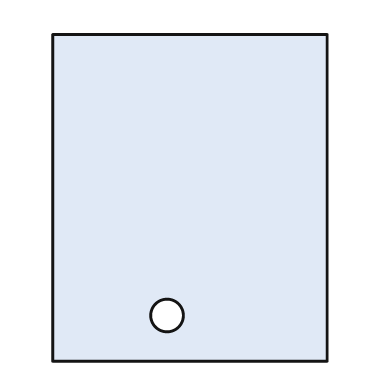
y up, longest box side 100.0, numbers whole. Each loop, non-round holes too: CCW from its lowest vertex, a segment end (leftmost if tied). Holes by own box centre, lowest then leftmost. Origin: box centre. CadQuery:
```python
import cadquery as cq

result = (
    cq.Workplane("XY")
    .moveTo(-42.0, -50.0)
    .lineTo(42.0, -50.0)
    .lineTo(42.0, 50.0)
    .lineTo(-42.0, 50.0)
    .close()
    .moveTo(-7.0, -36.0)
    .circle(5.0)
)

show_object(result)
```